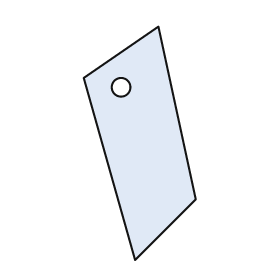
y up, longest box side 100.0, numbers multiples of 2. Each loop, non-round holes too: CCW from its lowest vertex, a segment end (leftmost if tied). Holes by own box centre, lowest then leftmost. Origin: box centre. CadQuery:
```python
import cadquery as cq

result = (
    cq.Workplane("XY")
    .moveTo(-2.0, -50.0)
    .lineTo(24.0, -24.0)
    .lineTo(8.0, 50.0)
    .lineTo(-24.0, 28.0)
    .close()
    .moveTo(-8.0, 24.0)
    .circle(4.0)
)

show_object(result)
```